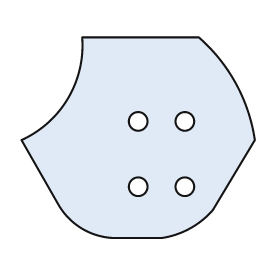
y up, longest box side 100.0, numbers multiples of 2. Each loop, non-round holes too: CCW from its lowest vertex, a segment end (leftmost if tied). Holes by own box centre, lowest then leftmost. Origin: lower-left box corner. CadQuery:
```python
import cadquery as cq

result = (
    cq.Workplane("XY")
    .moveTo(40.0, 0.0)
    .lineTo(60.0, 0.0)
    .threePointArc((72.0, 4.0), (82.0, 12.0))
    .lineTo(100.0, 42.0)
    .threePointArc((92.0, 66.0), (76.0, 86.0))
    .lineTo(26.0, 86.0)
    .threePointArc((20.0, 60.0), (0.0, 42.0))
    .lineTo(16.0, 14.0)
    .threePointArc((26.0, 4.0), (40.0, 0.0))
    .close()
    .moveTo(50.0, 22.0)
    .circle(4.0)
    .moveTo(70.0, 22.0)
    .circle(4.0)
    .moveTo(50.0, 50.0)
    .circle(4.0)
    .moveTo(70.0, 50.0)
    .circle(4.0)
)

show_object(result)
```